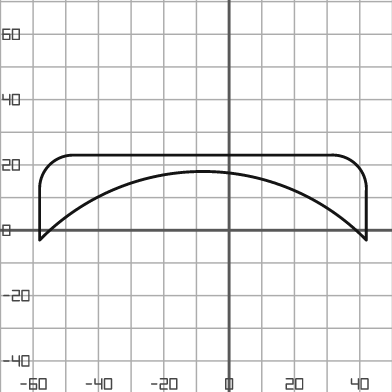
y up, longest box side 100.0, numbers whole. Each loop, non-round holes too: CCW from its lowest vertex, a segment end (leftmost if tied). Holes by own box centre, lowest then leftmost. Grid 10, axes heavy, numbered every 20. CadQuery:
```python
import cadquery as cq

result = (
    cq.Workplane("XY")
    .moveTo(-58.0, -3.0)
    .threePointArc((-8.0, 18.0), (42.0, -3.0))
    .lineTo(42.0, 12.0)
    .threePointArc((39.0, 20.0), (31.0, 23.0))
    .lineTo(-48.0, 23.0)
    .threePointArc((-55.0, 20.0), (-58.0, 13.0))
    .close()
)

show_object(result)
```